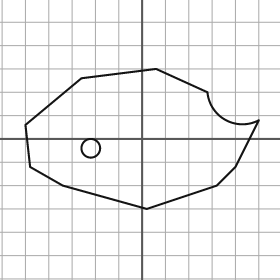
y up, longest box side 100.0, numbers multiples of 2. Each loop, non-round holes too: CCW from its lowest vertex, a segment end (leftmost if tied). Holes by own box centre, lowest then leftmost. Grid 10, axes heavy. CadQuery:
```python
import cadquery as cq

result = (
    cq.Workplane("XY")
    .moveTo(2.0, -30.0)
    .lineTo(32.0, -20.0)
    .lineTo(40.0, -12.0)
    .lineTo(50.0, 8.0)
    .threePointArc((36.0, 8.0), (28.0, 20.0))
    .lineTo(6.0, 30.0)
    .lineTo(-26.0, 26.0)
    .lineTo(-50.0, 6.0)
    .lineTo(-48.0, -12.0)
    .lineTo(-34.0, -20.0)
    .close()
    .moveTo(-22.0, -4.0)
    .circle(4.0)
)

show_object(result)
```